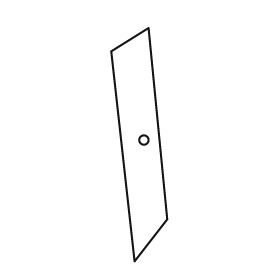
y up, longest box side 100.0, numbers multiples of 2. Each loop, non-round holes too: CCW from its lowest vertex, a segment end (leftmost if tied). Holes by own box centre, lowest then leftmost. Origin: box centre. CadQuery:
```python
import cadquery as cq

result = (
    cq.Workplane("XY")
    .moveTo(-2.0, -50.0)
    .lineTo(12.0, -32.0)
    .lineTo(4.0, 50.0)
    .lineTo(-12.0, 40.0)
    .close()
    .moveTo(2.0, 2.0)
    .circle(2.0)
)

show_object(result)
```